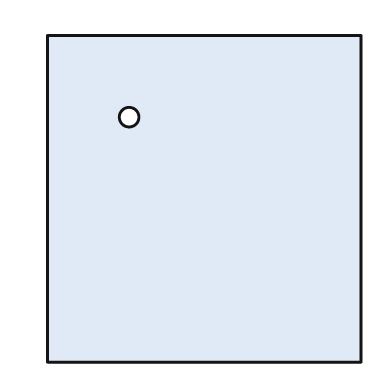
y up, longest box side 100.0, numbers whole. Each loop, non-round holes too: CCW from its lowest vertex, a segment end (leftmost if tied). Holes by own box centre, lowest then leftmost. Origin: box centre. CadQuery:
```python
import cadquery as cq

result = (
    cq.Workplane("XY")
    .moveTo(-48.0, -50.0)
    .lineTo(48.0, -50.0)
    .lineTo(48.0, 50.0)
    .lineTo(-48.0, 50.0)
    .close()
    .moveTo(-23.0, 25.0)
    .circle(3.0)
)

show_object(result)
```